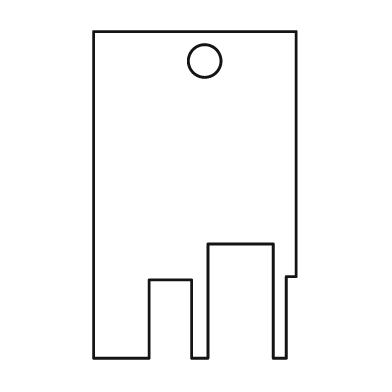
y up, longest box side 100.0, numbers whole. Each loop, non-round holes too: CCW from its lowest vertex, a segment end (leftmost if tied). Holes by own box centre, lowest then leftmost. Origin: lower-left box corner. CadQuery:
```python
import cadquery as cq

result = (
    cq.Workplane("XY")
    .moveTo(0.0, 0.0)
    .lineTo(17.0, 0.0)
    .lineTo(17.0, 24.0)
    .lineTo(30.0, 24.0)
    .lineTo(30.0, 0.0)
    .lineTo(35.0, 0.0)
    .lineTo(35.0, 35.0)
    .lineTo(55.0, 35.0)
    .lineTo(55.0, 0.0)
    .lineTo(59.0, 0.0)
    .lineTo(59.0, 25.0)
    .lineTo(62.0, 25.0)
    .lineTo(62.0, 100.0)
    .lineTo(0.0, 100.0)
    .close()
    .moveTo(34.0, 91.0)
    .circle(5.0)
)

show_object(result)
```